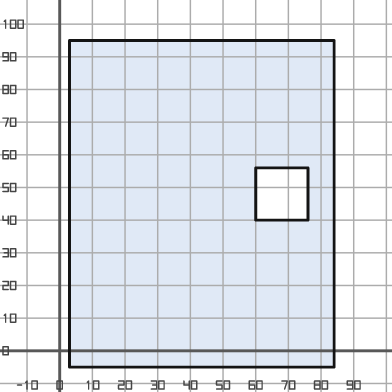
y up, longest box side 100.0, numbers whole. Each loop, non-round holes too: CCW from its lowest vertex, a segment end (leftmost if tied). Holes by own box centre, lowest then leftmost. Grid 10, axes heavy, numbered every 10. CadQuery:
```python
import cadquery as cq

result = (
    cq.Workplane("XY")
    .moveTo(3.0, -5.0)
    .lineTo(84.0, -5.0)
    .lineTo(84.0, 95.0)
    .lineTo(3.0, 95.0)
    .close()
    .moveTo(60.0, 40.0)
    .lineTo(76.0, 40.0)
    .lineTo(76.0, 56.0)
    .lineTo(60.0, 56.0)
    .close()
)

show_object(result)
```